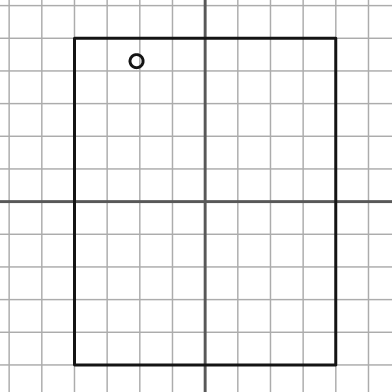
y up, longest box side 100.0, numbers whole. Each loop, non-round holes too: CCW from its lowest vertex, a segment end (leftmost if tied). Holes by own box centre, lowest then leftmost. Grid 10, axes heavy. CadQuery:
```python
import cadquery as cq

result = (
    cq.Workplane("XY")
    .moveTo(-40.0, -50.0)
    .lineTo(40.0, -50.0)
    .lineTo(40.0, 50.0)
    .lineTo(-40.0, 50.0)
    .close()
    .moveTo(-21.0, 43.0)
    .circle(2.0)
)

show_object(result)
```